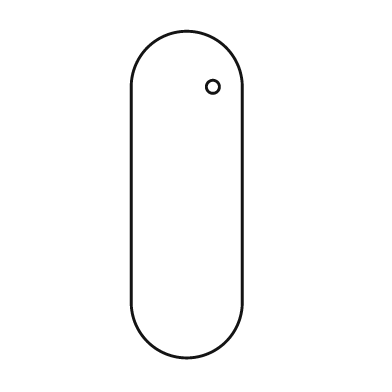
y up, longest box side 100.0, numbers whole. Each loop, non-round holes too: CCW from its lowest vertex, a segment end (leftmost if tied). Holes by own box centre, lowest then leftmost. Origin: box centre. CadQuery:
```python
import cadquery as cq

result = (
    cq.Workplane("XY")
    .moveTo(-17.0, -33.0)
    .threePointArc((0.0, -50.0), (17.0, -33.0))
    .lineTo(17.0, 33.0)
    .threePointArc((0.0, 50.0), (-17.0, 33.0))
    .close()
    .moveTo(8.0, 33.0)
    .circle(2.0)
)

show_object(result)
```